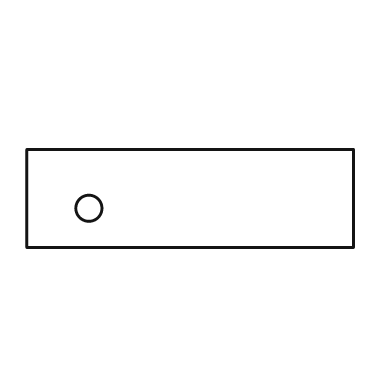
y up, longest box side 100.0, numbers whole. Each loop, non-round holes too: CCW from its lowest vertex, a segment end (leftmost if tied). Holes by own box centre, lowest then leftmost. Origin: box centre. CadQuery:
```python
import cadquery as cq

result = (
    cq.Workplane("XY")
    .moveTo(-50.0, -15.0)
    .lineTo(50.0, -15.0)
    .lineTo(50.0, 15.0)
    .lineTo(-50.0, 15.0)
    .close()
    .moveTo(-31.0, -3.0)
    .circle(4.0)
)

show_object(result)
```